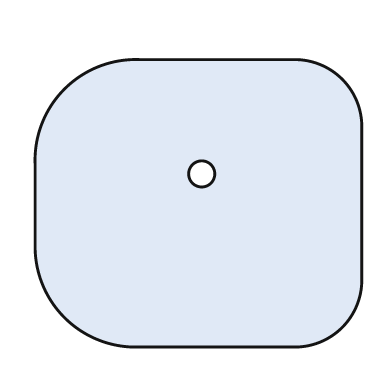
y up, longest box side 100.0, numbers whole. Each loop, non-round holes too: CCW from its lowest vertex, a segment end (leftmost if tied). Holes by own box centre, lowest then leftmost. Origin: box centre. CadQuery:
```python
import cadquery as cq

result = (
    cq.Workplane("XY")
    .moveTo(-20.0, -44.0)
    .lineTo(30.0, -44.0)
    .threePointArc((44.0, -38.0), (50.0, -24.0))
    .lineTo(50.0, 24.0)
    .threePointArc((44.0, 38.0), (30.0, 44.0))
    .lineTo(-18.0, 44.0)
    .threePointArc((-41.0, 35.0), (-50.0, 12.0))
    .lineTo(-50.0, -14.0)
    .threePointArc((-41.0, -35.0), (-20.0, -44.0))
    .close()
    .moveTo(1.0, 9.0)
    .circle(4.0)
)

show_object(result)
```